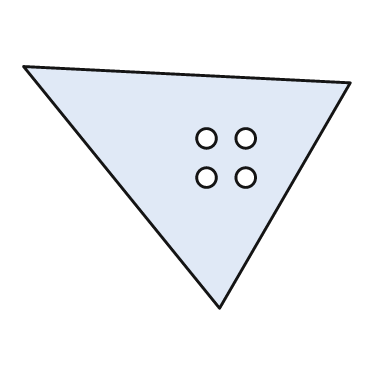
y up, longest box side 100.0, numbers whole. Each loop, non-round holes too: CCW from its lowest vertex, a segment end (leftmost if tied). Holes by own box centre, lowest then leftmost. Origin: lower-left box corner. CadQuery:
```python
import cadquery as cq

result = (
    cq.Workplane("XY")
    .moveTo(60.0, 0.0)
    .lineTo(100.0, 69.0)
    .lineTo(0.0, 74.0)
    .close()
    .moveTo(56.0, 40.0)
    .circle(3.0)
    .moveTo(68.0, 40.0)
    .circle(3.0)
    .moveTo(56.0, 52.0)
    .circle(3.0)
    .moveTo(68.0, 52.0)
    .circle(3.0)
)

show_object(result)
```